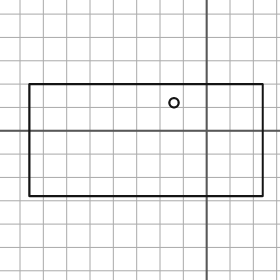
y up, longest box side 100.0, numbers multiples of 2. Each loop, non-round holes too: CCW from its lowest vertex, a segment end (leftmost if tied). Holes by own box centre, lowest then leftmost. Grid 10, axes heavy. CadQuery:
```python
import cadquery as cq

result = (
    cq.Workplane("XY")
    .moveTo(-76.0, -28.0)
    .lineTo(24.0, -28.0)
    .lineTo(24.0, 20.0)
    .lineTo(-76.0, 20.0)
    .close()
    .moveTo(-14.0, 12.0)
    .circle(2.0)
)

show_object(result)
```